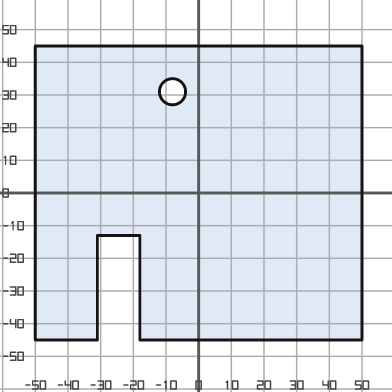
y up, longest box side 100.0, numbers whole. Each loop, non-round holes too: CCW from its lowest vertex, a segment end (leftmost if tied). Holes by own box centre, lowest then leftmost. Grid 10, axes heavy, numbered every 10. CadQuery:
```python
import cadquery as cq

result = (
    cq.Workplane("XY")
    .moveTo(-50.0, -45.0)
    .lineTo(-31.0, -45.0)
    .lineTo(-31.0, -13.0)
    .lineTo(-18.0, -13.0)
    .lineTo(-18.0, -45.0)
    .lineTo(50.0, -45.0)
    .lineTo(50.0, 45.0)
    .lineTo(-50.0, 45.0)
    .close()
    .moveTo(-8.0, 31.0)
    .circle(4.0)
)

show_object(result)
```